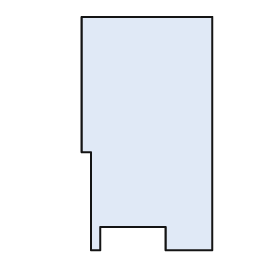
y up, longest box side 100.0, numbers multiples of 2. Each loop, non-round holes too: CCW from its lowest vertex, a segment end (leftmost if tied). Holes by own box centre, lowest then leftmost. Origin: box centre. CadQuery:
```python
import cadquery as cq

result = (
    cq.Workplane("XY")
    .moveTo(-24.0, -50.0)
    .lineTo(-20.0, -50.0)
    .lineTo(-20.0, -40.0)
    .lineTo(8.0, -40.0)
    .lineTo(8.0, -50.0)
    .lineTo(28.0, -50.0)
    .lineTo(28.0, 50.0)
    .lineTo(-28.0, 50.0)
    .lineTo(-28.0, -8.0)
    .lineTo(-24.0, -8.0)
    .close()
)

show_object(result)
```